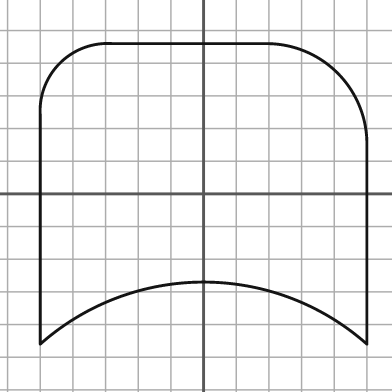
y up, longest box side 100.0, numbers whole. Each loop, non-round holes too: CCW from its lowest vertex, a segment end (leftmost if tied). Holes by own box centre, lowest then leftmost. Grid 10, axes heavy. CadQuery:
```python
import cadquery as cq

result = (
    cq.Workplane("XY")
    .moveTo(-50.0, -46.0)
    .threePointArc((0.0, -27.0), (50.0, -46.0))
    .lineTo(50.0, 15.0)
    .threePointArc((41.0, 37.0), (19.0, 46.0))
    .lineTo(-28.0, 46.0)
    .threePointArc((-44.0, 40.0), (-50.0, 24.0))
    .close()
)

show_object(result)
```